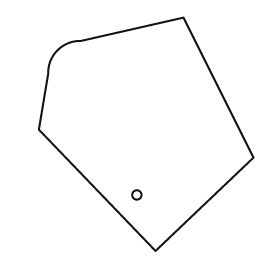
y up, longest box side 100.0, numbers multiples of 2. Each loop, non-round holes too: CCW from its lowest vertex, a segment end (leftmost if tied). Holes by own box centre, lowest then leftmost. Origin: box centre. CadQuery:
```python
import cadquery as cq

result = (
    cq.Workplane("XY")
    .moveTo(4.0, -50.0)
    .lineTo(46.0, -10.0)
    .lineTo(16.0, 50.0)
    .lineTo(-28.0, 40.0)
    .threePointArc((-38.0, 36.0), (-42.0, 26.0))
    .lineTo(-46.0, 2.0)
    .close()
    .moveTo(-4.0, -26.0)
    .circle(2.0)
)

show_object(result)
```